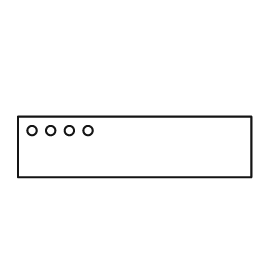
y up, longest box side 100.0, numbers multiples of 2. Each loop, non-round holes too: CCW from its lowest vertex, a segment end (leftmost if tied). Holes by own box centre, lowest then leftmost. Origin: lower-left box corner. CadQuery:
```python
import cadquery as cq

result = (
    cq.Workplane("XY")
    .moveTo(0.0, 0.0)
    .lineTo(100.0, 0.0)
    .lineTo(100.0, 26.0)
    .lineTo(0.0, 26.0)
    .close()
    .moveTo(6.0, 20.0)
    .circle(2.0)
    .moveTo(14.0, 20.0)
    .circle(2.0)
    .moveTo(22.0, 20.0)
    .circle(2.0)
    .moveTo(30.0, 20.0)
    .circle(2.0)
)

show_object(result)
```